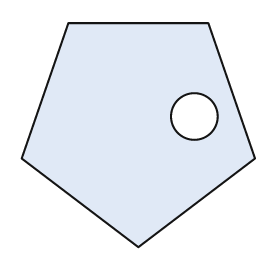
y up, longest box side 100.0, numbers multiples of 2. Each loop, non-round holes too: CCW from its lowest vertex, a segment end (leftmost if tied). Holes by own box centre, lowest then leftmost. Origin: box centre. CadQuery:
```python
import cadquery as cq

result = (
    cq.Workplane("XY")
    .moveTo(0.0, -48.0)
    .lineTo(50.0, -10.0)
    .lineTo(30.0, 48.0)
    .lineTo(-30.0, 48.0)
    .lineTo(-50.0, -10.0)
    .close()
    .moveTo(24.0, 8.0)
    .circle(10.0)
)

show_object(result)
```